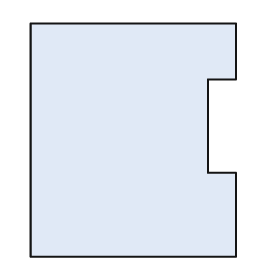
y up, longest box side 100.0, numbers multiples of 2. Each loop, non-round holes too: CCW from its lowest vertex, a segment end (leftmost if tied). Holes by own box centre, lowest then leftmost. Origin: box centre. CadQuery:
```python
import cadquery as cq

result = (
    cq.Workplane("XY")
    .moveTo(-44.0, -50.0)
    .lineTo(44.0, -50.0)
    .lineTo(44.0, -14.0)
    .lineTo(32.0, -14.0)
    .lineTo(32.0, 26.0)
    .lineTo(44.0, 26.0)
    .lineTo(44.0, 50.0)
    .lineTo(-44.0, 50.0)
    .close()
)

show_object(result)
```